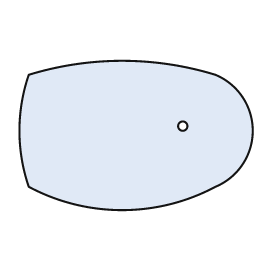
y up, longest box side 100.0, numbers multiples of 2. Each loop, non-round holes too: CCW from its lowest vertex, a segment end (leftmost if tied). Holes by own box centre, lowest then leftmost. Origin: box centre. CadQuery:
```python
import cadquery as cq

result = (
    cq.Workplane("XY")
    .moveTo(-46.0, -22.0)
    .threePointArc((-6.0, -32.0), (34.0, -22.0))
    .threePointArc((50.0, 2.0), (34.0, 26.0))
    .threePointArc((-6.0, 32.0), (-46.0, 26.0))
    .threePointArc((-50.0, 2.0), (-46.0, -22.0))
    .close()
    .moveTo(20.0, 4.0)
    .circle(2.0)
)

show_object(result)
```